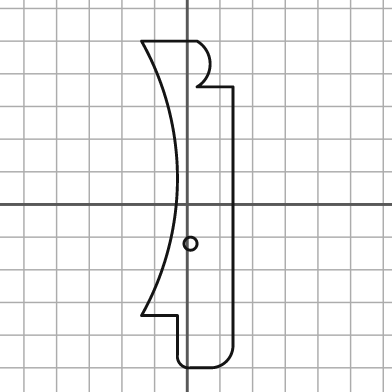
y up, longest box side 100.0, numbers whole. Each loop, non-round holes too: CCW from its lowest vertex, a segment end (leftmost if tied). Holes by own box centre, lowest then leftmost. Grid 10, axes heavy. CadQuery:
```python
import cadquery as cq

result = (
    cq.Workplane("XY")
    .moveTo(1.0, -50.0)
    .lineTo(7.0, -50.0)
    .threePointArc((12.0, -48.0), (14.0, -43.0))
    .lineTo(14.0, 36.0)
    .lineTo(3.0, 36.0)
    .threePointArc((7.0, 43.0), (3.0, 50.0))
    .lineTo(-14.0, 50.0)
    .threePointArc((-3.0, 8.0), (-14.0, -34.0))
    .lineTo(-3.0, -34.0)
    .lineTo(-3.0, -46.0)
    .threePointArc((-2.0, -49.0), (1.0, -50.0))
    .close()
    .moveTo(1.0, -12.0)
    .circle(2.0)
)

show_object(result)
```